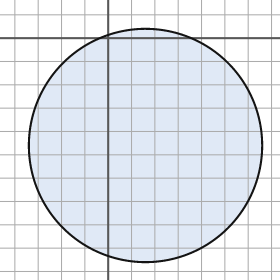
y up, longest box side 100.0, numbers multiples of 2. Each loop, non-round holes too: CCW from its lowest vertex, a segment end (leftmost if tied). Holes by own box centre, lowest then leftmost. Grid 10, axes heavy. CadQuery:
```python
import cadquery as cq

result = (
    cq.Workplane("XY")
    .moveTo(16.0, -46.0)
    .circle(50.0)
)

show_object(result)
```